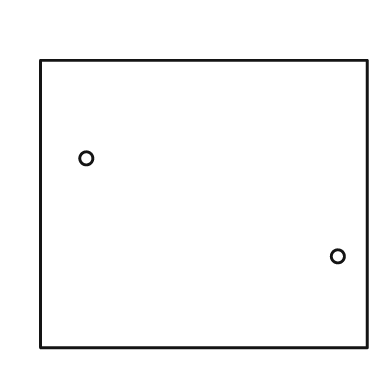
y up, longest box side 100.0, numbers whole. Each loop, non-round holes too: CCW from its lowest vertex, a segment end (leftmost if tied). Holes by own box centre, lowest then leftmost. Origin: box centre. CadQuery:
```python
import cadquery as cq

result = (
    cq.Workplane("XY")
    .moveTo(-50.0, -44.0)
    .lineTo(50.0, -44.0)
    .lineTo(50.0, 44.0)
    .lineTo(-50.0, 44.0)
    .close()
    .moveTo(41.0, -16.0)
    .circle(2.0)
    .moveTo(-36.0, 14.0)
    .circle(2.0)
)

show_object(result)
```